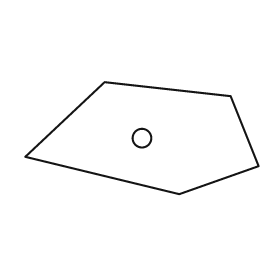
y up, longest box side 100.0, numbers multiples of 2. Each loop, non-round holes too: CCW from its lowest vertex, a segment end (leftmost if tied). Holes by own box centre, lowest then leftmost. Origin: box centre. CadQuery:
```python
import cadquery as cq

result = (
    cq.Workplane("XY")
    .moveTo(16.0, -24.0)
    .lineTo(50.0, -12.0)
    .lineTo(38.0, 18.0)
    .lineTo(-16.0, 24.0)
    .lineTo(-50.0, -8.0)
    .close()
    .moveTo(0.0, 0.0)
    .circle(4.0)
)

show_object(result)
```